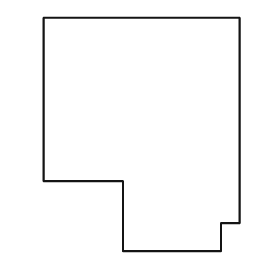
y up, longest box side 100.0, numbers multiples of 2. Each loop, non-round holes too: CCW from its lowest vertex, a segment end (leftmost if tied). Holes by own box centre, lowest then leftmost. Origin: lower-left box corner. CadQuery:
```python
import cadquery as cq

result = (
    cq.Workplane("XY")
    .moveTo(34.0, 0.0)
    .lineTo(76.0, 0.0)
    .lineTo(76.0, 12.0)
    .lineTo(84.0, 12.0)
    .lineTo(84.0, 100.0)
    .lineTo(0.0, 100.0)
    .lineTo(0.0, 30.0)
    .lineTo(34.0, 30.0)
    .close()
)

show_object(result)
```